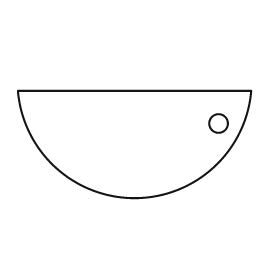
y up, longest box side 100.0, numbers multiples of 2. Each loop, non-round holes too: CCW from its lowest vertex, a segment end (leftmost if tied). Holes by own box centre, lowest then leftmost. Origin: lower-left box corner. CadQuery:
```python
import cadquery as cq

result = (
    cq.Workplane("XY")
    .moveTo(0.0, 46.0)
    .threePointArc((50.0, 0.0), (100.0, 46.0))
    .close()
    .moveTo(86.0, 32.0)
    .circle(4.0)
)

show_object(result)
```